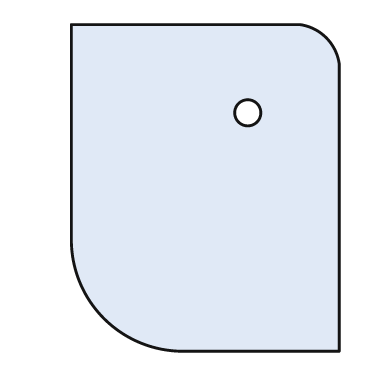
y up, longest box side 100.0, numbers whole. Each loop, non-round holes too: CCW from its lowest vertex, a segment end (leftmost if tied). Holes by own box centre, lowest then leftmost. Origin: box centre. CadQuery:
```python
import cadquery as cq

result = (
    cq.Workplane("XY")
    .moveTo(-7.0, -50.0)
    .lineTo(41.0, -50.0)
    .lineTo(41.0, 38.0)
    .threePointArc((37.0, 46.0), (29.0, 50.0))
    .lineTo(-41.0, 50.0)
    .lineTo(-41.0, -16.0)
    .threePointArc((-31.0, -40.0), (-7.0, -50.0))
    .close()
    .moveTo(13.0, 23.0)
    .circle(4.0)
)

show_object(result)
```